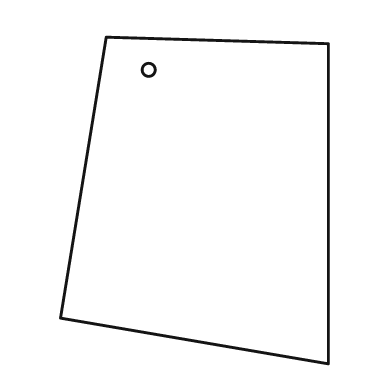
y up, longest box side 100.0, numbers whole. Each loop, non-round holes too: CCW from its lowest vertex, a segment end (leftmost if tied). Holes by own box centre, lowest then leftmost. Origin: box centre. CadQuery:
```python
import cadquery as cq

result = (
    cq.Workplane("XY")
    .moveTo(41.0, -50.0)
    .lineTo(41.0, 48.0)
    .lineTo(-27.0, 50.0)
    .lineTo(-41.0, -36.0)
    .close()
    .moveTo(-14.0, 40.0)
    .circle(2.0)
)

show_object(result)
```